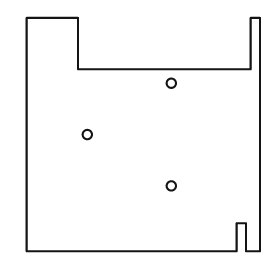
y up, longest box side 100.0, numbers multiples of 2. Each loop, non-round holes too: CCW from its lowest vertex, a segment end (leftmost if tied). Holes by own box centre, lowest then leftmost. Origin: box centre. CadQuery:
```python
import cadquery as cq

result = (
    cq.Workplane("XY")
    .moveTo(-50.0, -50.0)
    .lineTo(40.0, -50.0)
    .lineTo(40.0, -38.0)
    .lineTo(44.0, -38.0)
    .lineTo(44.0, -50.0)
    .lineTo(50.0, -50.0)
    .lineTo(50.0, 50.0)
    .lineTo(46.0, 50.0)
    .lineTo(46.0, 28.0)
    .lineTo(-28.0, 28.0)
    .lineTo(-28.0, 50.0)
    .lineTo(-50.0, 50.0)
    .close()
    .moveTo(12.0, -22.0)
    .circle(2.0)
    .moveTo(-24.0, 0.0)
    .circle(2.0)
    .moveTo(12.0, 22.0)
    .circle(2.0)
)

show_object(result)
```